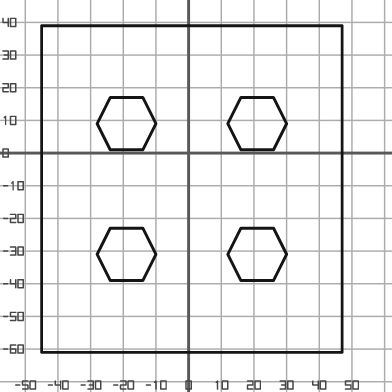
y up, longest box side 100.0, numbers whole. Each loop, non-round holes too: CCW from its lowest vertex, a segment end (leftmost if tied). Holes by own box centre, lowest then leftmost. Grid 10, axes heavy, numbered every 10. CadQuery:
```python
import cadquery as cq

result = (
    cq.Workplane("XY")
    .moveTo(-45.0, -61.0)
    .lineTo(47.0, -61.0)
    .lineTo(47.0, 39.0)
    .lineTo(-45.0, 39.0)
    .close()
    .moveTo(-24.0, -39.0)
    .lineTo(-14.0, -39.0)
    .lineTo(-10.0, -31.0)
    .lineTo(-14.0, -23.0)
    .lineTo(-24.0, -23.0)
    .lineTo(-28.0, -31.0)
    .close()
    .moveTo(16.0, -39.0)
    .lineTo(26.0, -39.0)
    .lineTo(30.0, -31.0)
    .lineTo(26.0, -23.0)
    .lineTo(16.0, -23.0)
    .lineTo(12.0, -31.0)
    .close()
    .moveTo(-24.0, 1.0)
    .lineTo(-14.0, 1.0)
    .lineTo(-10.0, 9.0)
    .lineTo(-14.0, 17.0)
    .lineTo(-24.0, 17.0)
    .lineTo(-28.0, 9.0)
    .close()
    .moveTo(16.0, 1.0)
    .lineTo(26.0, 1.0)
    .lineTo(30.0, 9.0)
    .lineTo(26.0, 17.0)
    .lineTo(16.0, 17.0)
    .lineTo(12.0, 9.0)
    .close()
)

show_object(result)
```